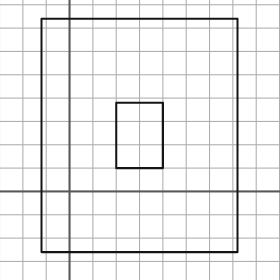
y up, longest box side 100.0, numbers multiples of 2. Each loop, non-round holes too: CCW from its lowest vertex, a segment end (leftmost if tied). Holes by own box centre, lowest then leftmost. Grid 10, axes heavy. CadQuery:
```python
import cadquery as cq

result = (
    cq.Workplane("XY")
    .moveTo(-12.0, -26.0)
    .lineTo(72.0, -26.0)
    .lineTo(72.0, 74.0)
    .lineTo(-12.0, 74.0)
    .close()
    .moveTo(20.0, 10.0)
    .lineTo(40.0, 10.0)
    .lineTo(40.0, 38.0)
    .lineTo(20.0, 38.0)
    .close()
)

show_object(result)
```